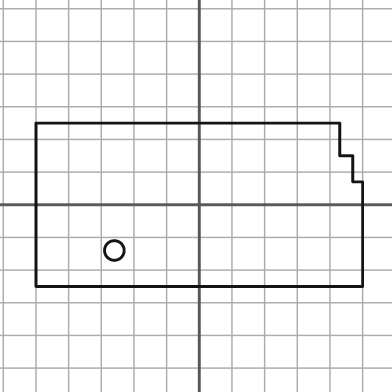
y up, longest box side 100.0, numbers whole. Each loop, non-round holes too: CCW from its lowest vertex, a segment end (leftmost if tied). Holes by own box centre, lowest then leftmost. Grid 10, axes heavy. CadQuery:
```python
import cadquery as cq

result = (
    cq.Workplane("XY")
    .moveTo(-50.0, -25.0)
    .lineTo(50.0, -25.0)
    .lineTo(50.0, 7.0)
    .lineTo(47.0, 7.0)
    .lineTo(47.0, 15.0)
    .lineTo(43.0, 15.0)
    .lineTo(43.0, 25.0)
    .lineTo(-50.0, 25.0)
    .close()
    .moveTo(-26.0, -14.0)
    .circle(3.0)
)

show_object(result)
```